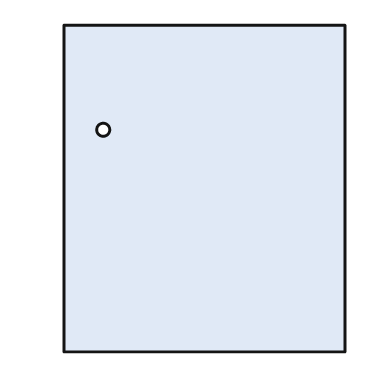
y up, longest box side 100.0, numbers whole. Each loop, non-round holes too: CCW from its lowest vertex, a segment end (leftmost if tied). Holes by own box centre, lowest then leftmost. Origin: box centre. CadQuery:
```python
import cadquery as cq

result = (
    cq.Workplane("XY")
    .moveTo(-43.0, -50.0)
    .lineTo(43.0, -50.0)
    .lineTo(43.0, 50.0)
    .lineTo(-43.0, 50.0)
    .close()
    .moveTo(-31.0, 18.0)
    .circle(2.0)
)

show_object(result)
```